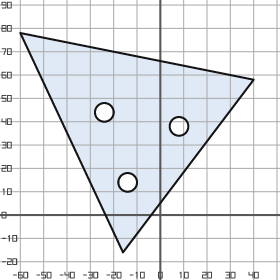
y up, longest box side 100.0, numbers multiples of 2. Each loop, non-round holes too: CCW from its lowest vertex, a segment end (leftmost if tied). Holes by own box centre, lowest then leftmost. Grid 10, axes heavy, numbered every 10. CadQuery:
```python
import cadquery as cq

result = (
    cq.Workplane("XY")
    .moveTo(-16.0, -16.0)
    .lineTo(40.0, 58.0)
    .lineTo(-60.0, 78.0)
    .close()
    .moveTo(-14.0, 14.0)
    .circle(4.0)
    .moveTo(8.0, 38.0)
    .circle(4.0)
    .moveTo(-24.0, 44.0)
    .circle(4.0)
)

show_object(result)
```